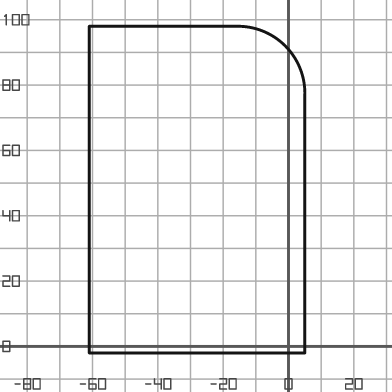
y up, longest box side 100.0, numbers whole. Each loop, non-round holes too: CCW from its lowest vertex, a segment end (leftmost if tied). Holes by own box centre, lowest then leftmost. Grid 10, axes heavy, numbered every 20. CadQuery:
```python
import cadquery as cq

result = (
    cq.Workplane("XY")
    .moveTo(-61.0, -2.0)
    .lineTo(5.0, -2.0)
    .lineTo(5.0, 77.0)
    .threePointArc((-1.0, 92.0), (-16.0, 98.0))
    .lineTo(-61.0, 98.0)
    .close()
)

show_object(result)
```